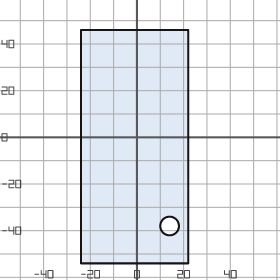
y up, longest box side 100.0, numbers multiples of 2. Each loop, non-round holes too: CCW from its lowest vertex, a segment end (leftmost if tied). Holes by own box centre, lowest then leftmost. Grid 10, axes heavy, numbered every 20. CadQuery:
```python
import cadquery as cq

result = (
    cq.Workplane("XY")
    .moveTo(-24.0, -54.0)
    .lineTo(22.0, -54.0)
    .lineTo(22.0, 46.0)
    .lineTo(-24.0, 46.0)
    .close()
    .moveTo(14.0, -38.0)
    .circle(4.0)
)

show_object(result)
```